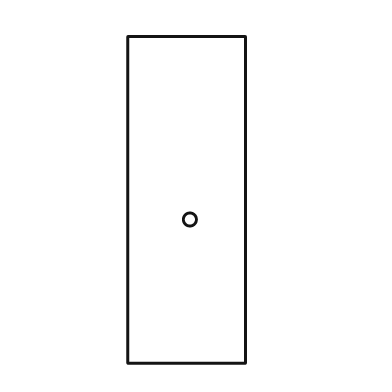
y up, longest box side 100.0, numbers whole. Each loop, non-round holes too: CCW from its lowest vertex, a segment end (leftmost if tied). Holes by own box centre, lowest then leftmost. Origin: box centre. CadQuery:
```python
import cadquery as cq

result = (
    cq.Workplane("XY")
    .moveTo(-18.0, -50.0)
    .lineTo(18.0, -50.0)
    .lineTo(18.0, 50.0)
    .lineTo(-18.0, 50.0)
    .close()
    .moveTo(1.0, -6.0)
    .circle(2.0)
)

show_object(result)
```